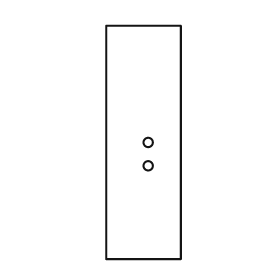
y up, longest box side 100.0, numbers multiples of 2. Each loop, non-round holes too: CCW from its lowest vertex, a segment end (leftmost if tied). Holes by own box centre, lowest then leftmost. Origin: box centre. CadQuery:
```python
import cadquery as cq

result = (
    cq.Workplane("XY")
    .moveTo(-16.0, -50.0)
    .lineTo(16.0, -50.0)
    .lineTo(16.0, 50.0)
    .lineTo(-16.0, 50.0)
    .close()
    .moveTo(2.0, -10.0)
    .circle(2.0)
    .moveTo(2.0, 0.0)
    .circle(2.0)
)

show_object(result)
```